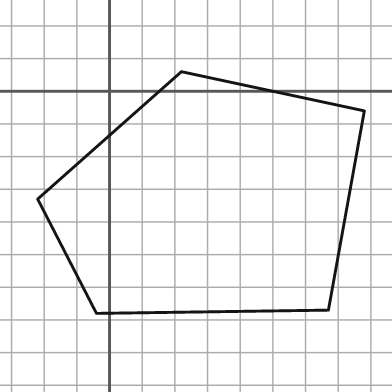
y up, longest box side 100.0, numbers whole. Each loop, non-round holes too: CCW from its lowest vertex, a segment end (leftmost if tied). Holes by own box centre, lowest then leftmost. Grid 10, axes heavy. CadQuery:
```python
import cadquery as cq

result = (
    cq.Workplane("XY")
    .moveTo(-4.0, -68.0)
    .lineTo(67.0, -67.0)
    .lineTo(78.0, -6.0)
    .lineTo(22.0, 6.0)
    .lineTo(-22.0, -33.0)
    .close()
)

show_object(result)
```